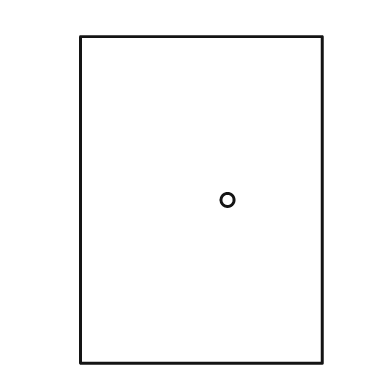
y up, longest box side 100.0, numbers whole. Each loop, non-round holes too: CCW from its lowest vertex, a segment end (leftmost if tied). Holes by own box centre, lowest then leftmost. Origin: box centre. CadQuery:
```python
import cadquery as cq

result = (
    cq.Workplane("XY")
    .moveTo(-37.0, -50.0)
    .lineTo(37.0, -50.0)
    .lineTo(37.0, 50.0)
    .lineTo(-37.0, 50.0)
    .close()
    .moveTo(8.0, 0.0)
    .circle(2.0)
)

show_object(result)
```